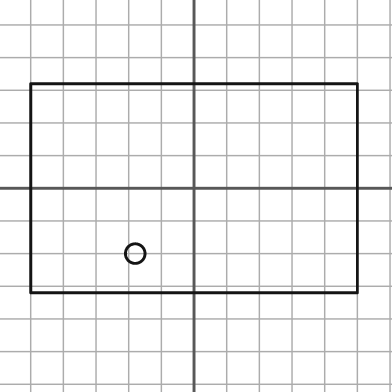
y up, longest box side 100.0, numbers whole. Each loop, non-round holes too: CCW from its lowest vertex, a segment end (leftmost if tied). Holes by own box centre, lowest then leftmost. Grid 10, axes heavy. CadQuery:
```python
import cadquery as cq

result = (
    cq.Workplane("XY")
    .moveTo(-50.0, -32.0)
    .lineTo(50.0, -32.0)
    .lineTo(50.0, 32.0)
    .lineTo(-50.0, 32.0)
    .close()
    .moveTo(-18.0, -20.0)
    .circle(3.0)
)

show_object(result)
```